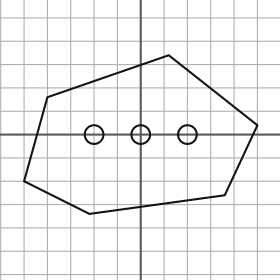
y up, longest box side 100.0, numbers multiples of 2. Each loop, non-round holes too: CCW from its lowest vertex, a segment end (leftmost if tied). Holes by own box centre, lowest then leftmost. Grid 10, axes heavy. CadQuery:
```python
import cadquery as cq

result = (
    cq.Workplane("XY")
    .moveTo(-22.0, -34.0)
    .lineTo(36.0, -26.0)
    .lineTo(50.0, 4.0)
    .lineTo(12.0, 34.0)
    .lineTo(-40.0, 16.0)
    .lineTo(-50.0, -20.0)
    .close()
    .moveTo(-20.0, 0.0)
    .circle(4.0)
    .moveTo(0.0, 0.0)
    .circle(4.0)
    .moveTo(20.0, 0.0)
    .circle(4.0)
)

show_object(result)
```